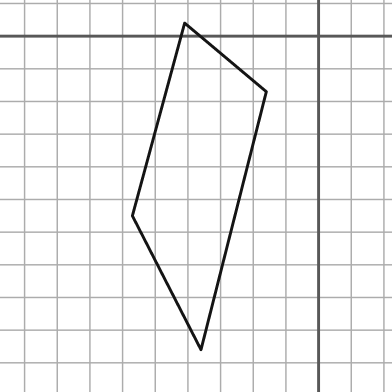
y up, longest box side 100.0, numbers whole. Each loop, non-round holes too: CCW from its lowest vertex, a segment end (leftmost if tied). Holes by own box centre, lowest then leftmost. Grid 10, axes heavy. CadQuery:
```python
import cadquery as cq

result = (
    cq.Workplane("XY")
    .moveTo(-36.0, -96.0)
    .lineTo(-16.0, -17.0)
    .lineTo(-41.0, 4.0)
    .lineTo(-57.0, -55.0)
    .close()
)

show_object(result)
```